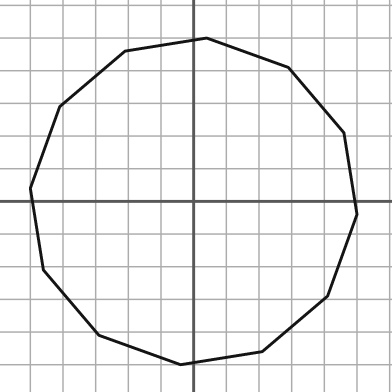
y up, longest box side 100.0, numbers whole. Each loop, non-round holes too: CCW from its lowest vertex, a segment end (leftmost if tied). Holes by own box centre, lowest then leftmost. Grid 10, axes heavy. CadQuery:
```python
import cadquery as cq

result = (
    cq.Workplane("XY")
    .moveTo(-4.0, -50.0)
    .lineTo(21.0, -46.0)
    .lineTo(41.0, -29.0)
    .lineTo(50.0, -4.0)
    .lineTo(46.0, 21.0)
    .lineTo(29.0, 41.0)
    .lineTo(4.0, 50.0)
    .lineTo(-21.0, 46.0)
    .lineTo(-41.0, 29.0)
    .lineTo(-50.0, 4.0)
    .lineTo(-46.0, -21.0)
    .lineTo(-29.0, -41.0)
    .close()
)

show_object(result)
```